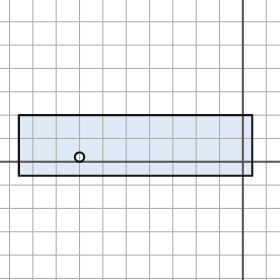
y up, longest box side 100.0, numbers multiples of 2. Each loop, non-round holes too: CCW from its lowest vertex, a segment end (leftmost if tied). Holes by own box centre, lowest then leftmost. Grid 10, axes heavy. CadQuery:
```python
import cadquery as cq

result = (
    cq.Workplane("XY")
    .moveTo(-96.0, -6.0)
    .lineTo(4.0, -6.0)
    .lineTo(4.0, 20.0)
    .lineTo(-96.0, 20.0)
    .close()
    .moveTo(-70.0, 2.0)
    .circle(2.0)
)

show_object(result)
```